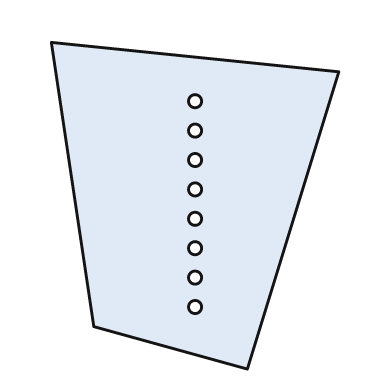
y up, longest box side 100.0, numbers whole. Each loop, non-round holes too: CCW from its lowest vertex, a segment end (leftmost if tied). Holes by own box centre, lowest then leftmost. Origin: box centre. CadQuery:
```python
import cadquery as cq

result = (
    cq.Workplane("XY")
    .moveTo(16.0, -50.0)
    .lineTo(44.0, 41.0)
    .lineTo(-44.0, 50.0)
    .lineTo(-31.0, -37.0)
    .close()
    .moveTo(0.0, -31.0)
    .circle(2.0)
    .moveTo(0.0, -22.0)
    .circle(2.0)
    .moveTo(0.0, -13.0)
    .circle(2.0)
    .moveTo(0.0, -4.0)
    .circle(2.0)
    .moveTo(0.0, 5.0)
    .circle(2.0)
    .moveTo(0.0, 14.0)
    .circle(2.0)
    .moveTo(0.0, 23.0)
    .circle(2.0)
    .moveTo(0.0, 32.0)
    .circle(2.0)
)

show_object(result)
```